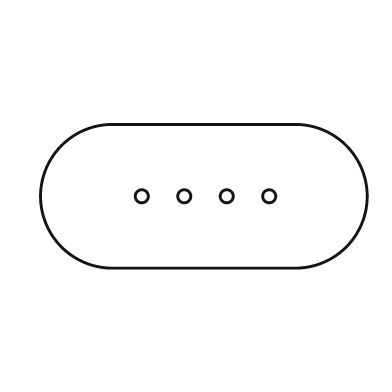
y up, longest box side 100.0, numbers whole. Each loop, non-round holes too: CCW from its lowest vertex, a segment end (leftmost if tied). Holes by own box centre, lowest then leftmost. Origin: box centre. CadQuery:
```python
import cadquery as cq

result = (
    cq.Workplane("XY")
    .moveTo(-28.0, -22.0)
    .lineTo(28.0, -22.0)
    .threePointArc((50.0, 0.0), (28.0, 22.0))
    .lineTo(-28.0, 22.0)
    .threePointArc((-50.0, 0.0), (-28.0, -22.0))
    .close()
    .moveTo(-19.0, 0.0)
    .circle(2.0)
    .moveTo(-6.0, 0.0)
    .circle(2.0)
    .moveTo(7.0, 0.0)
    .circle(2.0)
    .moveTo(20.0, 0.0)
    .circle(2.0)
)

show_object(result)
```